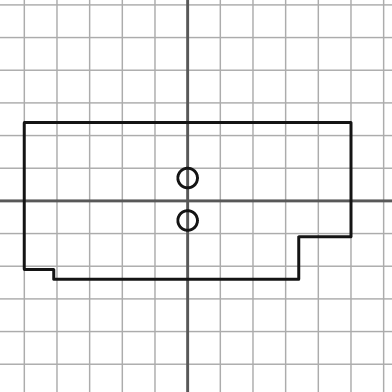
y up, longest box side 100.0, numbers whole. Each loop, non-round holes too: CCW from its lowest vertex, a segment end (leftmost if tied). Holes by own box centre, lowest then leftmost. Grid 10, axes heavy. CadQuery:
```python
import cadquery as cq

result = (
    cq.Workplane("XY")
    .moveTo(-41.0, -24.0)
    .lineTo(34.0, -24.0)
    .lineTo(34.0, -11.0)
    .lineTo(50.0, -11.0)
    .lineTo(50.0, 24.0)
    .lineTo(-50.0, 24.0)
    .lineTo(-50.0, -21.0)
    .lineTo(-41.0, -21.0)
    .close()
    .moveTo(0.0, -6.0)
    .circle(3.0)
    .moveTo(0.0, 7.0)
    .circle(3.0)
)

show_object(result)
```